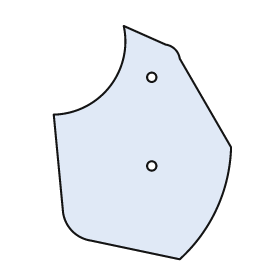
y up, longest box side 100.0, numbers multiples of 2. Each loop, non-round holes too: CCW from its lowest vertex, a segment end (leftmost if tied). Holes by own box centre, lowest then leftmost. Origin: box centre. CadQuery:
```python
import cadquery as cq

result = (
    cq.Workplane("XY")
    .moveTo(16.0, -50.0)
    .threePointArc((32.0, -28.0), (38.0, -2.0))
    .lineTo(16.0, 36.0)
    .threePointArc((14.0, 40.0), (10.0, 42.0))
    .lineTo(-8.0, 50.0)
    .threePointArc((-14.0, 24.0), (-38.0, 12.0))
    .lineTo(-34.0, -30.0)
    .threePointArc((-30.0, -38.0), (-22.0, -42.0))
    .close()
    .moveTo(4.0, -10.0)
    .circle(2.0)
    .moveTo(4.0, 28.0)
    .circle(2.0)
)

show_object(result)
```